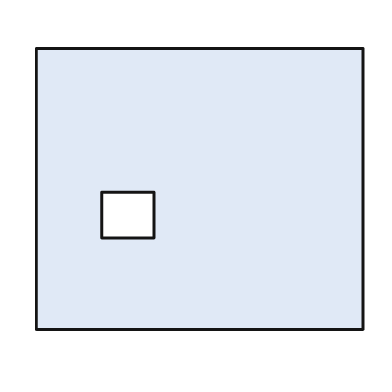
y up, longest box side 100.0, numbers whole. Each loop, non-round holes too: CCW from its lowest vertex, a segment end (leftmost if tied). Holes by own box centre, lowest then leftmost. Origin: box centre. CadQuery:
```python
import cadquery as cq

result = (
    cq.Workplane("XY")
    .moveTo(-50.0, -43.0)
    .lineTo(50.0, -43.0)
    .lineTo(50.0, 43.0)
    .lineTo(-50.0, 43.0)
    .close()
    .moveTo(-30.0, -15.0)
    .lineTo(-14.0, -15.0)
    .lineTo(-14.0, -1.0)
    .lineTo(-30.0, -1.0)
    .close()
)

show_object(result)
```